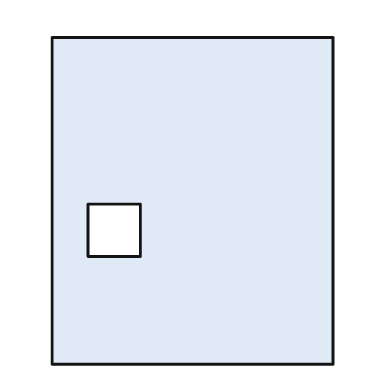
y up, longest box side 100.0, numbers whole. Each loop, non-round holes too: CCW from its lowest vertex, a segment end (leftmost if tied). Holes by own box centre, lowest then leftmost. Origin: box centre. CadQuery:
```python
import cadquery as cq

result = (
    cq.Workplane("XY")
    .moveTo(-43.0, -50.0)
    .lineTo(43.0, -50.0)
    .lineTo(43.0, 50.0)
    .lineTo(-43.0, 50.0)
    .close()
    .moveTo(-32.0, -17.0)
    .lineTo(-16.0, -17.0)
    .lineTo(-16.0, -1.0)
    .lineTo(-32.0, -1.0)
    .close()
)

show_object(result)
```